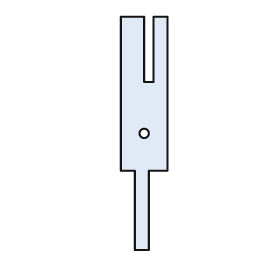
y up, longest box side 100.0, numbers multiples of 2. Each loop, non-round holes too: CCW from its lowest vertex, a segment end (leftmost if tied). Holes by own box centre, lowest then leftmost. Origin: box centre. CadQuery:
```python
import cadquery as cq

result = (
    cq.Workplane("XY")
    .moveTo(-4.0, -50.0)
    .lineTo(2.0, -50.0)
    .lineTo(2.0, -16.0)
    .lineTo(10.0, -16.0)
    .lineTo(10.0, 50.0)
    .lineTo(4.0, 50.0)
    .lineTo(4.0, 22.0)
    .lineTo(0.0, 22.0)
    .lineTo(0.0, 50.0)
    .lineTo(-10.0, 50.0)
    .lineTo(-10.0, -16.0)
    .lineTo(-4.0, -16.0)
    .close()
    .moveTo(0.0, 0.0)
    .circle(2.0)
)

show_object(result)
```